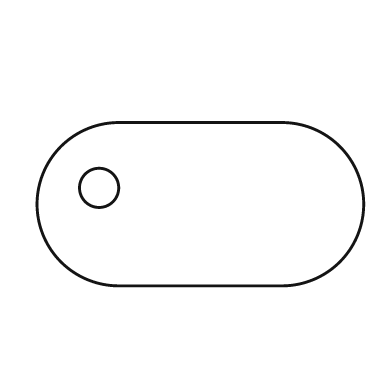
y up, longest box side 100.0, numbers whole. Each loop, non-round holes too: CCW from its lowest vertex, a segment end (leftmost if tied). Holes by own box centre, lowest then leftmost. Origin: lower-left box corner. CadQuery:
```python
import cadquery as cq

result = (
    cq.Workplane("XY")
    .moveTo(25.0, 0.0)
    .lineTo(75.0, 0.0)
    .threePointArc((100.0, 25.0), (75.0, 50.0))
    .lineTo(25.0, 50.0)
    .threePointArc((0.0, 25.0), (25.0, 0.0))
    .close()
    .moveTo(19.0, 30.0)
    .circle(6.0)
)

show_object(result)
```